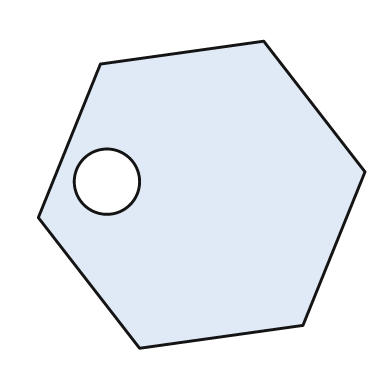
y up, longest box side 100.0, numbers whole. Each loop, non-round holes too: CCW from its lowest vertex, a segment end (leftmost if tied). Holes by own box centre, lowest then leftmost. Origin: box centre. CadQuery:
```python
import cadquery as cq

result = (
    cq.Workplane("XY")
    .moveTo(-19.0, -47.0)
    .lineTo(31.0, -40.0)
    .lineTo(50.0, 7.0)
    .lineTo(19.0, 47.0)
    .lineTo(-31.0, 40.0)
    .lineTo(-50.0, -7.0)
    .close()
    .moveTo(-29.0, 4.0)
    .circle(10.0)
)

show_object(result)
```